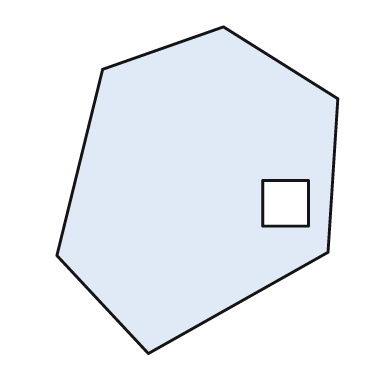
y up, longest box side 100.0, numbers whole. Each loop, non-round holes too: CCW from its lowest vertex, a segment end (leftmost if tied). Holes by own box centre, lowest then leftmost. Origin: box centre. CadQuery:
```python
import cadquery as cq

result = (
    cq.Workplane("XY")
    .moveTo(-15.0, -50.0)
    .lineTo(40.0, -19.0)
    .lineTo(43.0, 28.0)
    .lineTo(8.0, 50.0)
    .lineTo(-29.0, 37.0)
    .lineTo(-43.0, -20.0)
    .close()
    .moveTo(20.0, -11.0)
    .lineTo(34.0, -11.0)
    .lineTo(34.0, 3.0)
    .lineTo(20.0, 3.0)
    .close()
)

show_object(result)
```